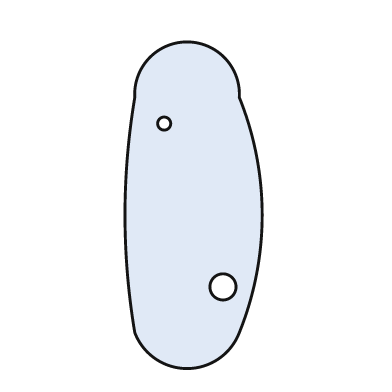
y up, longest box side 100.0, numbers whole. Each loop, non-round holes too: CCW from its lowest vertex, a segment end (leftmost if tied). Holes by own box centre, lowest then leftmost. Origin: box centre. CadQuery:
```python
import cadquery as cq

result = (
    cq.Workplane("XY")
    .moveTo(-18.0, -39.0)
    .threePointArc((-2.0, -50.0), (14.0, -39.0))
    .threePointArc((21.0, -3.0), (14.0, 33.0))
    .threePointArc((-2.0, 50.0), (-18.0, 33.0))
    .threePointArc((-21.0, -3.0), (-18.0, -39.0))
    .close()
    .moveTo(9.0, -25.0)
    .circle(4.0)
    .moveTo(-9.0, 25.0)
    .circle(2.0)
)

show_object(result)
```